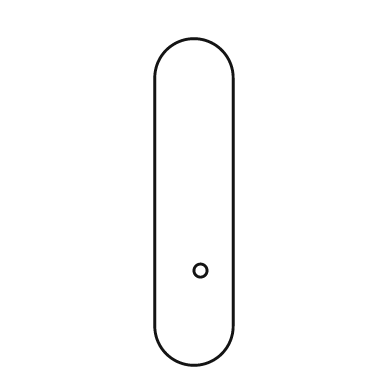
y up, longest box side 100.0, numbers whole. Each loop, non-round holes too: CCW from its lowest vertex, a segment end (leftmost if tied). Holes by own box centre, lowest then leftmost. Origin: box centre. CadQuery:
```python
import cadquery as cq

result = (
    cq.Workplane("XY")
    .moveTo(-12.0, -38.0)
    .threePointArc((0.0, -50.0), (12.0, -38.0))
    .lineTo(12.0, 38.0)
    .threePointArc((0.0, 50.0), (-12.0, 38.0))
    .close()
    .moveTo(2.0, -21.0)
    .circle(2.0)
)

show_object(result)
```